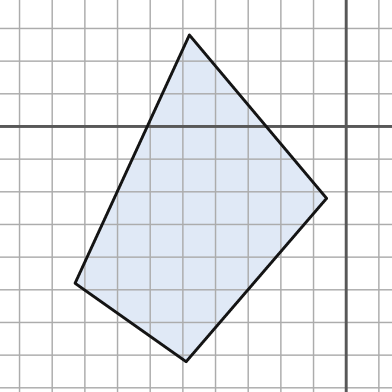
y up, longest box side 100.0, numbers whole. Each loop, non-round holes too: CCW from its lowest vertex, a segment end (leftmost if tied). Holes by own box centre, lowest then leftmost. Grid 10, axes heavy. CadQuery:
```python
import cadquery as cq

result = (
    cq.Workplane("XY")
    .moveTo(-49.0, -72.0)
    .lineTo(-6.0, -22.0)
    .lineTo(-48.0, 28.0)
    .lineTo(-83.0, -48.0)
    .close()
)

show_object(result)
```